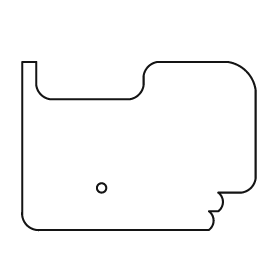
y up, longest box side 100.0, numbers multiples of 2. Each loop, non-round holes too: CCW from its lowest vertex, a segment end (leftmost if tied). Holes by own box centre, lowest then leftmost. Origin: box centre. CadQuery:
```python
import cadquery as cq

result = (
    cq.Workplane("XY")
    .moveTo(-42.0, -36.0)
    .lineTo(30.0, -36.0)
    .threePointArc((32.0, -32.0), (30.0, -28.0))
    .lineTo(34.0, -28.0)
    .threePointArc((36.0, -24.0), (34.0, -20.0))
    .lineTo(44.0, -20.0)
    .threePointArc((48.0, -18.0), (50.0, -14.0))
    .lineTo(50.0, 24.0)
    .threePointArc((46.0, 32.0), (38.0, 36.0))
    .lineTo(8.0, 36.0)
    .threePointArc((4.0, 34.0), (2.0, 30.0))
    .lineTo(2.0, 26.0)
    .threePointArc((0.0, 22.0), (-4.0, 20.0))
    .lineTo(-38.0, 20.0)
    .threePointArc((-42.0, 22.0), (-44.0, 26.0))
    .lineTo(-44.0, 36.0)
    .lineTo(-50.0, 36.0)
    .lineTo(-50.0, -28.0)
    .threePointArc((-48.0, -34.0), (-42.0, -36.0))
    .close()
    .moveTo(-16.0, -18.0)
    .circle(2.0)
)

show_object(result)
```